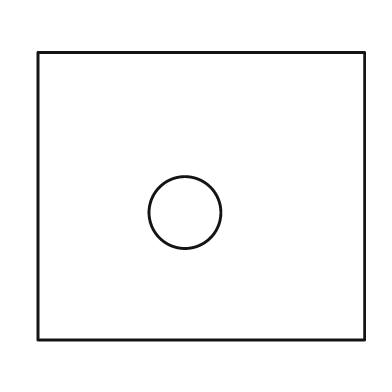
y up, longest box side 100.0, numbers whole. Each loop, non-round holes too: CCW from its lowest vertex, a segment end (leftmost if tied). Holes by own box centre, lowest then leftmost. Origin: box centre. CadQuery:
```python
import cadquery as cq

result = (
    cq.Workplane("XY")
    .moveTo(-50.0, -44.0)
    .lineTo(50.0, -44.0)
    .lineTo(50.0, 44.0)
    .lineTo(-50.0, 44.0)
    .close()
    .moveTo(-5.0, -5.0)
    .circle(11.0)
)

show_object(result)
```